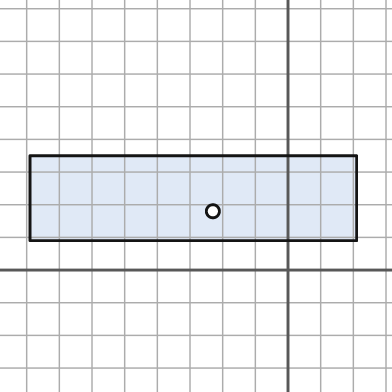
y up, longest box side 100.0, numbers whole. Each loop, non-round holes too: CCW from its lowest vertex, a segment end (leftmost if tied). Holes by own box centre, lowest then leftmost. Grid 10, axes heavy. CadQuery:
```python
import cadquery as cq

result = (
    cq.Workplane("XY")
    .moveTo(-79.0, 9.0)
    .lineTo(21.0, 9.0)
    .lineTo(21.0, 35.0)
    .lineTo(-79.0, 35.0)
    .close()
    .moveTo(-23.0, 18.0)
    .circle(2.0)
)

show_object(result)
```